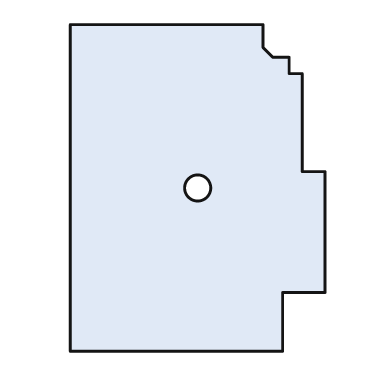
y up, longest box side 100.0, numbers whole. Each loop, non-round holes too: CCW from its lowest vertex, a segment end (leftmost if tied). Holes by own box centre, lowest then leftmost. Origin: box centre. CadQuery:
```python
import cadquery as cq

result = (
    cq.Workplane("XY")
    .moveTo(-39.0, -50.0)
    .lineTo(26.0, -50.0)
    .lineTo(26.0, -32.0)
    .lineTo(39.0, -32.0)
    .lineTo(39.0, 5.0)
    .lineTo(32.0, 5.0)
    .lineTo(32.0, 35.0)
    .lineTo(28.0, 35.0)
    .lineTo(28.0, 40.0)
    .lineTo(23.0, 40.0)
    .lineTo(20.0, 43.0)
    .lineTo(20.0, 50.0)
    .lineTo(-39.0, 50.0)
    .close()
    .moveTo(0.0, 0.0)
    .circle(4.0)
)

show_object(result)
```